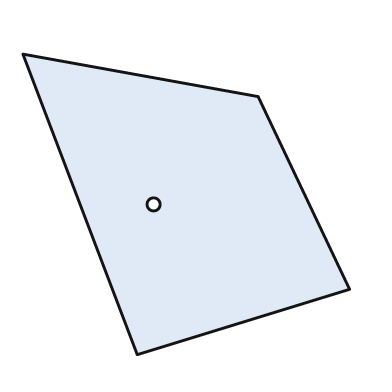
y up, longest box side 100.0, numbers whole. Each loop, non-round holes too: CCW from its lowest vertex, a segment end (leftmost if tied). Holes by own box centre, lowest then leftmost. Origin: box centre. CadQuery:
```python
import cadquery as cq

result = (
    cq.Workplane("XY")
    .moveTo(-15.0, -46.0)
    .lineTo(50.0, -26.0)
    .lineTo(22.0, 33.0)
    .lineTo(-50.0, 46.0)
    .close()
    .moveTo(-10.0, 0.0)
    .circle(2.0)
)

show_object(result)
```